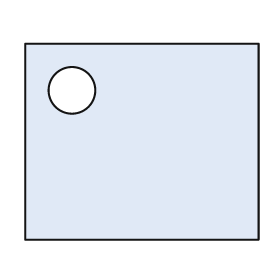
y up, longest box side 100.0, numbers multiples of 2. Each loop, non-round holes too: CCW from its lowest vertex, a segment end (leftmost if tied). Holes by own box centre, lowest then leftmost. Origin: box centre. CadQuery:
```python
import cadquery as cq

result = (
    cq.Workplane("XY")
    .moveTo(-50.0, -42.0)
    .lineTo(50.0, -42.0)
    .lineTo(50.0, 42.0)
    .lineTo(-50.0, 42.0)
    .close()
    .moveTo(-30.0, 22.0)
    .circle(10.0)
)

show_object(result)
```